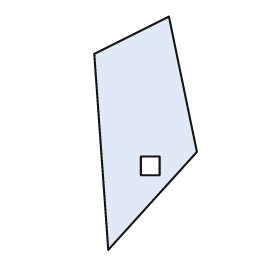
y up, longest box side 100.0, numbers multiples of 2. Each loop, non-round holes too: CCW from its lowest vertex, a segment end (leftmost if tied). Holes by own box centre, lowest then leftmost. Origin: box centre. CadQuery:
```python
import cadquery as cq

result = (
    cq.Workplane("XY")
    .moveTo(-16.0, -50.0)
    .lineTo(22.0, -8.0)
    .lineTo(10.0, 50.0)
    .lineTo(-22.0, 34.0)
    .close()
    .moveTo(-2.0, -18.0)
    .lineTo(6.0, -18.0)
    .lineTo(6.0, -10.0)
    .lineTo(-2.0, -10.0)
    .close()
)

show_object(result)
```